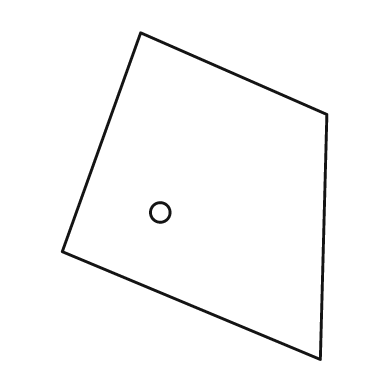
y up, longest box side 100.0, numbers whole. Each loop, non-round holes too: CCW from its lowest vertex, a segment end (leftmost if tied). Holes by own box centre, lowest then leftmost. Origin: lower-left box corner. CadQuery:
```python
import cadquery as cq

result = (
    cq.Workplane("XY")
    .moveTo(79.0, 0.0)
    .lineTo(81.0, 75.0)
    .lineTo(24.0, 100.0)
    .lineTo(0.0, 33.0)
    .close()
    .moveTo(30.0, 45.0)
    .circle(3.0)
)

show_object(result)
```